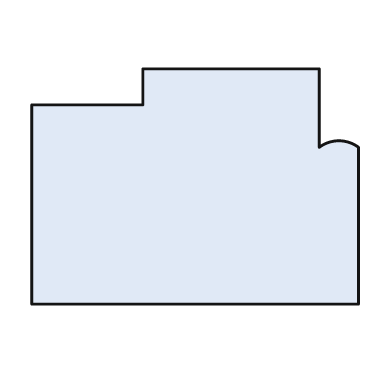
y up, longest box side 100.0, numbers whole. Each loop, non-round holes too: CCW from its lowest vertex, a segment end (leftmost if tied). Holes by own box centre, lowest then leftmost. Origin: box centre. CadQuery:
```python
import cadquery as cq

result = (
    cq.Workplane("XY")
    .moveTo(-50.0, -36.0)
    .lineTo(50.0, -36.0)
    .lineTo(50.0, 12.0)
    .threePointArc((44.0, 14.0), (38.0, 12.0))
    .lineTo(38.0, 36.0)
    .lineTo(-16.0, 36.0)
    .lineTo(-16.0, 25.0)
    .lineTo(-50.0, 25.0)
    .close()
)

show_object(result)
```